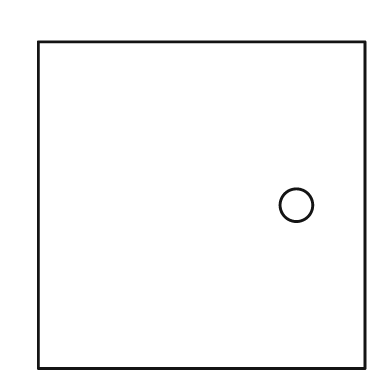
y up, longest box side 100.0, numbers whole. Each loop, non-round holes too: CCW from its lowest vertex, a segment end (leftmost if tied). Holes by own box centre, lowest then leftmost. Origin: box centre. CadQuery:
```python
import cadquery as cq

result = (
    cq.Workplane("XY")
    .moveTo(-50.0, -50.0)
    .lineTo(50.0, -50.0)
    .lineTo(50.0, 50.0)
    .lineTo(-50.0, 50.0)
    .close()
    .moveTo(29.0, 0.0)
    .circle(5.0)
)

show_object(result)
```